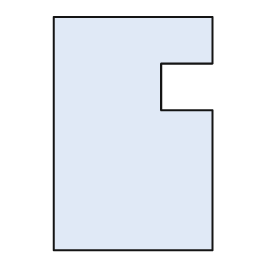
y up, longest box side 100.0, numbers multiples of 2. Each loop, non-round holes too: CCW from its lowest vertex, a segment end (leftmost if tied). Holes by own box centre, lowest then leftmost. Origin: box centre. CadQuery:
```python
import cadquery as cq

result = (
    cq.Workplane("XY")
    .moveTo(-34.0, -50.0)
    .lineTo(34.0, -50.0)
    .lineTo(34.0, 10.0)
    .lineTo(12.0, 10.0)
    .lineTo(12.0, 30.0)
    .lineTo(34.0, 30.0)
    .lineTo(34.0, 50.0)
    .lineTo(-34.0, 50.0)
    .close()
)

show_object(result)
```